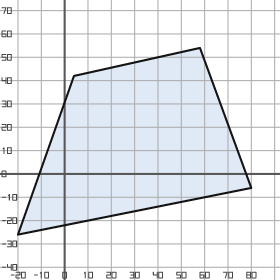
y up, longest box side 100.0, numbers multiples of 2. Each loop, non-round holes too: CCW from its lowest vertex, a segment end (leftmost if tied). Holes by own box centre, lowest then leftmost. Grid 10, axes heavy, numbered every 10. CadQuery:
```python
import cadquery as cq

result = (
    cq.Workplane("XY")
    .moveTo(-20.0, -26.0)
    .lineTo(80.0, -6.0)
    .lineTo(58.0, 54.0)
    .lineTo(4.0, 42.0)
    .close()
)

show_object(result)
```